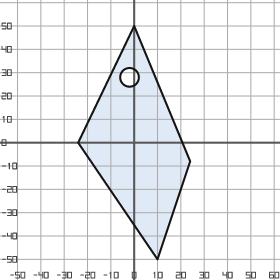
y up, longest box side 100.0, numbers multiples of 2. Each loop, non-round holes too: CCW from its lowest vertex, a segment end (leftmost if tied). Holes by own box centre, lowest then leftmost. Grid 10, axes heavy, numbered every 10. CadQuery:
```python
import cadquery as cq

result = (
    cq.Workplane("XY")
    .moveTo(10.0, -50.0)
    .lineTo(24.0, -8.0)
    .lineTo(0.0, 50.0)
    .lineTo(-24.0, 0.0)
    .close()
    .moveTo(-2.0, 28.0)
    .circle(4.0)
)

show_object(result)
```